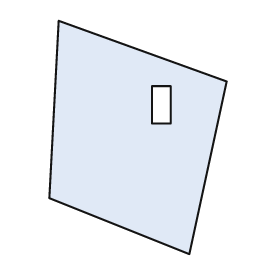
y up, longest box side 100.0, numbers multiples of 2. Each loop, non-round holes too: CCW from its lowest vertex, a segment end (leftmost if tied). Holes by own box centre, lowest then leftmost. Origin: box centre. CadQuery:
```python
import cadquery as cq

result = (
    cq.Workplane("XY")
    .moveTo(22.0, -50.0)
    .lineTo(38.0, 24.0)
    .lineTo(-34.0, 50.0)
    .lineTo(-38.0, -26.0)
    .close()
    .moveTo(6.0, 6.0)
    .lineTo(14.0, 6.0)
    .lineTo(14.0, 22.0)
    .lineTo(6.0, 22.0)
    .close()
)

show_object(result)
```